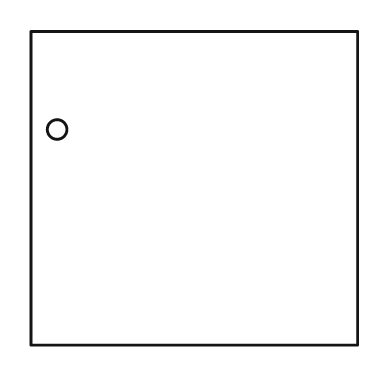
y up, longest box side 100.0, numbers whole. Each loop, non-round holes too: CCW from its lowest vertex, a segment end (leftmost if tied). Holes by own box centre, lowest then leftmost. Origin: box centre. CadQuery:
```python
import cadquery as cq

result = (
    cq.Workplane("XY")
    .moveTo(-50.0, -48.0)
    .lineTo(50.0, -48.0)
    .lineTo(50.0, 48.0)
    .lineTo(-50.0, 48.0)
    .close()
    .moveTo(-42.0, 18.0)
    .circle(3.0)
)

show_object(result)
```